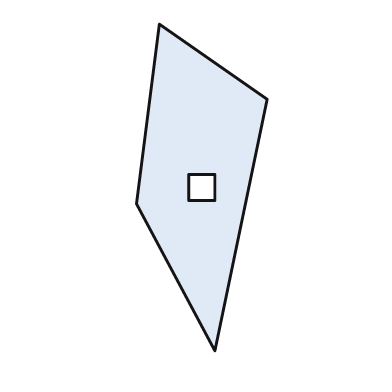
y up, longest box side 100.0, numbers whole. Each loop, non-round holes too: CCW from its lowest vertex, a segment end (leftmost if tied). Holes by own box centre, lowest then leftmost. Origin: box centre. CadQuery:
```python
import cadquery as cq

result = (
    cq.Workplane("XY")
    .moveTo(4.0, -50.0)
    .lineTo(20.0, 27.0)
    .lineTo(-13.0, 50.0)
    .lineTo(-20.0, -5.0)
    .close()
    .moveTo(-4.0, -4.0)
    .lineTo(4.0, -4.0)
    .lineTo(4.0, 4.0)
    .lineTo(-4.0, 4.0)
    .close()
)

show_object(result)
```